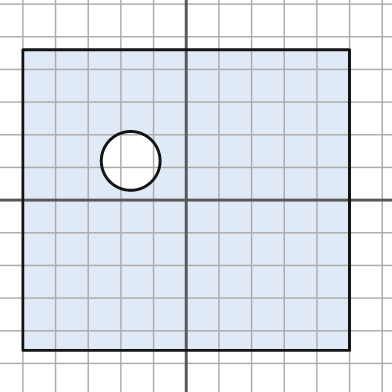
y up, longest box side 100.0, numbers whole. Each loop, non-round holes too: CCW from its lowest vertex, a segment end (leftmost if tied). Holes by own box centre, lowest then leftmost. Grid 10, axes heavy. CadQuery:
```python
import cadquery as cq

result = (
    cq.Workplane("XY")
    .moveTo(-50.0, -46.0)
    .lineTo(50.0, -46.0)
    .lineTo(50.0, 46.0)
    .lineTo(-50.0, 46.0)
    .close()
    .moveTo(-17.0, 12.0)
    .circle(9.0)
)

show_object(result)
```